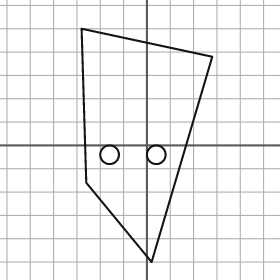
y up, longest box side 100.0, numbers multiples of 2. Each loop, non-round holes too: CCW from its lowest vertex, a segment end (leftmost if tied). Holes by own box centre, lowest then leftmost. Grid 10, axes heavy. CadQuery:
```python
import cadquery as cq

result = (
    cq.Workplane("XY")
    .moveTo(2.0, -50.0)
    .lineTo(28.0, 38.0)
    .lineTo(-28.0, 50.0)
    .lineTo(-26.0, -16.0)
    .close()
    .moveTo(-16.0, -4.0)
    .circle(4.0)
    .moveTo(4.0, -4.0)
    .circle(4.0)
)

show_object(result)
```